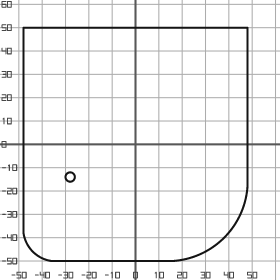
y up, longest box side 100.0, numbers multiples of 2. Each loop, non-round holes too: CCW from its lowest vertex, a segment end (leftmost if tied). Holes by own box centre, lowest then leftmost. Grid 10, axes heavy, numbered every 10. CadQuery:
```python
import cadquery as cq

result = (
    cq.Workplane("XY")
    .moveTo(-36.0, -50.0)
    .lineTo(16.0, -50.0)
    .threePointArc((38.0, -40.0), (48.0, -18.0))
    .lineTo(48.0, 50.0)
    .lineTo(-48.0, 50.0)
    .lineTo(-48.0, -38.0)
    .threePointArc((-44.0, -46.0), (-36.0, -50.0))
    .close()
    .moveTo(-28.0, -14.0)
    .circle(2.0)
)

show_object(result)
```